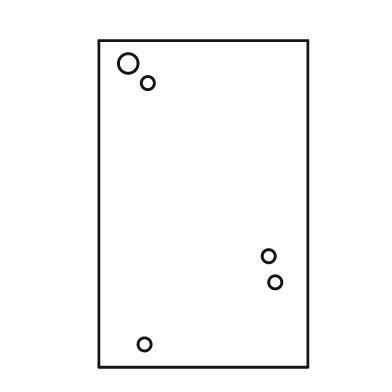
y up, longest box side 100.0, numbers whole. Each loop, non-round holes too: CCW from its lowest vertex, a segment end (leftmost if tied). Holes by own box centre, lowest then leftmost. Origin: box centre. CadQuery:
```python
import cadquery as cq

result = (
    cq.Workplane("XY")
    .moveTo(-32.0, -50.0)
    .lineTo(32.0, -50.0)
    .lineTo(32.0, 50.0)
    .lineTo(-32.0, 50.0)
    .close()
    .moveTo(-18.0, -43.0)
    .circle(2.0)
    .moveTo(22.0, -24.0)
    .circle(2.0)
    .moveTo(20.0, -16.0)
    .circle(2.0)
    .moveTo(-17.0, 37.0)
    .circle(2.0)
    .moveTo(-23.0, 43.0)
    .circle(3.0)
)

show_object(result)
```